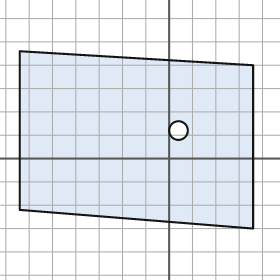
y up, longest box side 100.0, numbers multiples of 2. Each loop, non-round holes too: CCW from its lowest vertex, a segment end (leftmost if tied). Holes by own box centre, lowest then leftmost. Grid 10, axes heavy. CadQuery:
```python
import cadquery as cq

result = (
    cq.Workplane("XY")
    .moveTo(36.0, -30.0)
    .lineTo(36.0, 40.0)
    .lineTo(-64.0, 46.0)
    .lineTo(-64.0, -22.0)
    .close()
    .moveTo(4.0, 12.0)
    .circle(4.0)
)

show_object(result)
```